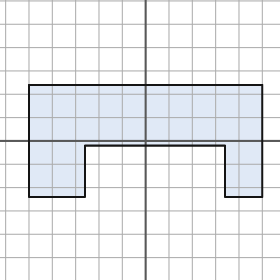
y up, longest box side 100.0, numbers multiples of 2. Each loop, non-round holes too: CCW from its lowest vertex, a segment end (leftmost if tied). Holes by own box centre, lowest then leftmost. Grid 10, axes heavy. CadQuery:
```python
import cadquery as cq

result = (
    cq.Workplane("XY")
    .moveTo(-50.0, -24.0)
    .lineTo(-26.0, -24.0)
    .lineTo(-26.0, -2.0)
    .lineTo(34.0, -2.0)
    .lineTo(34.0, -24.0)
    .lineTo(50.0, -24.0)
    .lineTo(50.0, 24.0)
    .lineTo(-50.0, 24.0)
    .close()
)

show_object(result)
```